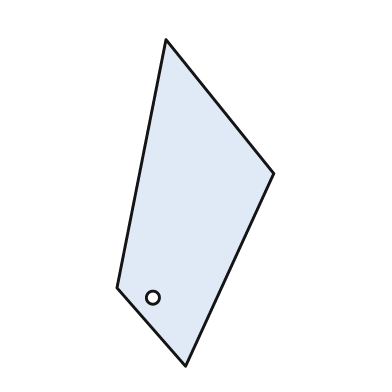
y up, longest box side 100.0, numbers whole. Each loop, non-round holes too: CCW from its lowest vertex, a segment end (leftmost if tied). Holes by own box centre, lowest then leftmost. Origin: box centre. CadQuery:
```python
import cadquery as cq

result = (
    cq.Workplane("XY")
    .moveTo(-3.0, -50.0)
    .lineTo(24.0, 9.0)
    .lineTo(-9.0, 50.0)
    .lineTo(-24.0, -26.0)
    .close()
    .moveTo(-13.0, -29.0)
    .circle(2.0)
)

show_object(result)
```